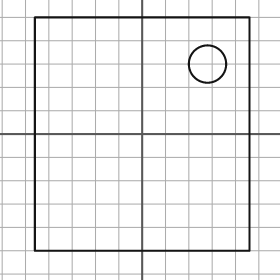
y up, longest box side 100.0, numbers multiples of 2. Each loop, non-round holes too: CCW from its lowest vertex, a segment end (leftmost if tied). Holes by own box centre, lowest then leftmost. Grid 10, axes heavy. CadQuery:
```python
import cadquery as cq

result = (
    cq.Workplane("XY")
    .moveTo(-46.0, -50.0)
    .lineTo(46.0, -50.0)
    .lineTo(46.0, 50.0)
    .lineTo(-46.0, 50.0)
    .close()
    .moveTo(28.0, 30.0)
    .circle(8.0)
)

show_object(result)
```